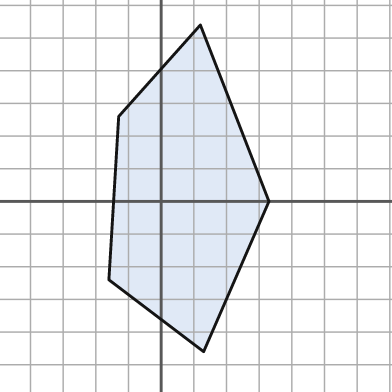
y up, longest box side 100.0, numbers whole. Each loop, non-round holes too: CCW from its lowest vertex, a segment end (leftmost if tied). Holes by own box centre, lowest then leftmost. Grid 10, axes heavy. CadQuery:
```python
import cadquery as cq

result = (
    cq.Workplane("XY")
    .moveTo(13.0, -46.0)
    .lineTo(33.0, 0.0)
    .lineTo(12.0, 54.0)
    .lineTo(-13.0, 26.0)
    .lineTo(-16.0, -24.0)
    .close()
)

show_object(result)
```